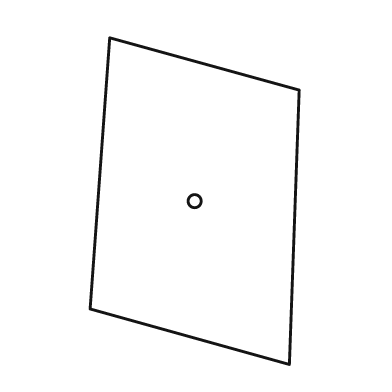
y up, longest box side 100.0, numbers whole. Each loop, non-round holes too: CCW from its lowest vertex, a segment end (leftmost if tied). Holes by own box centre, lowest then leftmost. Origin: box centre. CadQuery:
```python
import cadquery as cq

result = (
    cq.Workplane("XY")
    .moveTo(29.0, -50.0)
    .lineTo(32.0, 34.0)
    .lineTo(-26.0, 50.0)
    .lineTo(-32.0, -33.0)
    .close()
    .moveTo(0.0, 0.0)
    .circle(2.0)
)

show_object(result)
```